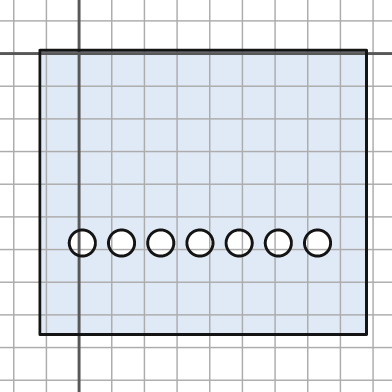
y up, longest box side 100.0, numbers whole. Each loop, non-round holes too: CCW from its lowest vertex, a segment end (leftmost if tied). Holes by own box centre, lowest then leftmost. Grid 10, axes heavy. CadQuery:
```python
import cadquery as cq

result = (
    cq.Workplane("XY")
    .moveTo(-12.0, -86.0)
    .lineTo(88.0, -86.0)
    .lineTo(88.0, 1.0)
    .lineTo(-12.0, 1.0)
    .close()
    .moveTo(1.0, -58.0)
    .circle(4.0)
    .moveTo(13.0, -58.0)
    .circle(4.0)
    .moveTo(25.0, -58.0)
    .circle(4.0)
    .moveTo(37.0, -58.0)
    .circle(4.0)
    .moveTo(49.0, -58.0)
    .circle(4.0)
    .moveTo(61.0, -58.0)
    .circle(4.0)
    .moveTo(73.0, -58.0)
    .circle(4.0)
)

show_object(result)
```